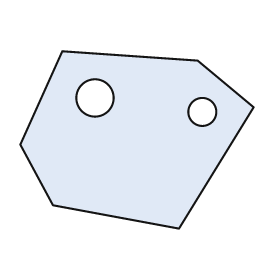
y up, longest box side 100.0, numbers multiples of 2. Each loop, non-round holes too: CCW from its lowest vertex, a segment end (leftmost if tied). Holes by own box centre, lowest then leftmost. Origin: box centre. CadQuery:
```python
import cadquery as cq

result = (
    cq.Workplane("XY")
    .moveTo(18.0, -38.0)
    .lineTo(50.0, 14.0)
    .lineTo(26.0, 34.0)
    .lineTo(-32.0, 38.0)
    .lineTo(-50.0, -2.0)
    .lineTo(-36.0, -28.0)
    .close()
    .moveTo(28.0, 12.0)
    .circle(6.0)
    .moveTo(-18.0, 18.0)
    .circle(8.0)
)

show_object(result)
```